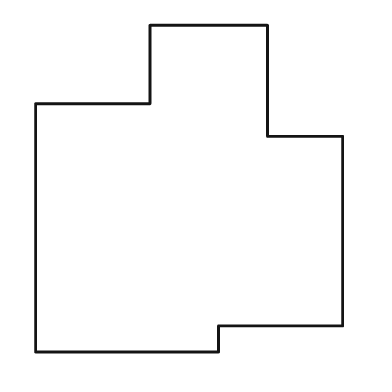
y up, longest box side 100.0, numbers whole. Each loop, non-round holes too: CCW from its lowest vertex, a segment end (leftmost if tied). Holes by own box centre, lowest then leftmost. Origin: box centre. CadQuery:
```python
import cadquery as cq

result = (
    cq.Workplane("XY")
    .moveTo(-47.0, -50.0)
    .lineTo(9.0, -50.0)
    .lineTo(9.0, -42.0)
    .lineTo(47.0, -42.0)
    .lineTo(47.0, 16.0)
    .lineTo(24.0, 16.0)
    .lineTo(24.0, 50.0)
    .lineTo(-12.0, 50.0)
    .lineTo(-12.0, 26.0)
    .lineTo(-47.0, 26.0)
    .close()
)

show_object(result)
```